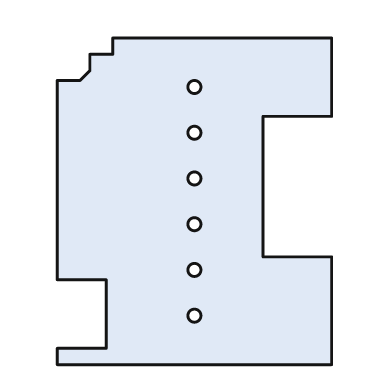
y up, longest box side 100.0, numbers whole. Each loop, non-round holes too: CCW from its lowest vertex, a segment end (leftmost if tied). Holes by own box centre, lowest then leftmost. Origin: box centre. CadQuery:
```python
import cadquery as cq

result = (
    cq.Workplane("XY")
    .moveTo(-42.0, -50.0)
    .lineTo(42.0, -50.0)
    .lineTo(42.0, -17.0)
    .lineTo(21.0, -17.0)
    .lineTo(21.0, 26.0)
    .lineTo(42.0, 26.0)
    .lineTo(42.0, 50.0)
    .lineTo(-25.0, 50.0)
    .lineTo(-25.0, 45.0)
    .lineTo(-32.0, 45.0)
    .lineTo(-32.0, 40.0)
    .lineTo(-35.0, 37.0)
    .lineTo(-42.0, 37.0)
    .lineTo(-42.0, -24.0)
    .lineTo(-27.0, -24.0)
    .lineTo(-27.0, -45.0)
    .lineTo(-42.0, -45.0)
    .close()
    .moveTo(0.0, -35.0)
    .circle(2.0)
    .moveTo(0.0, -21.0)
    .circle(2.0)
    .moveTo(0.0, -7.0)
    .circle(2.0)
    .moveTo(0.0, 7.0)
    .circle(2.0)
    .moveTo(0.0, 21.0)
    .circle(2.0)
    .moveTo(0.0, 35.0)
    .circle(2.0)
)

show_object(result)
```